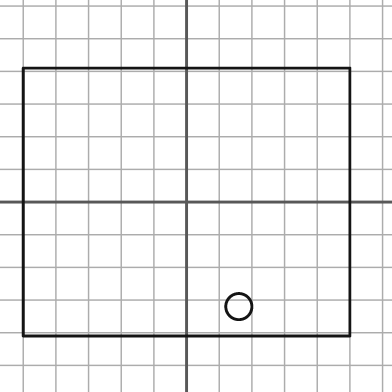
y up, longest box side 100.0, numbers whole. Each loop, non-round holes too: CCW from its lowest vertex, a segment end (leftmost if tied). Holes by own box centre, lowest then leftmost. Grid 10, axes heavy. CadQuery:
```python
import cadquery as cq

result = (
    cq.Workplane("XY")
    .moveTo(-50.0, -41.0)
    .lineTo(50.0, -41.0)
    .lineTo(50.0, 41.0)
    .lineTo(-50.0, 41.0)
    .close()
    .moveTo(16.0, -32.0)
    .circle(4.0)
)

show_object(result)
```